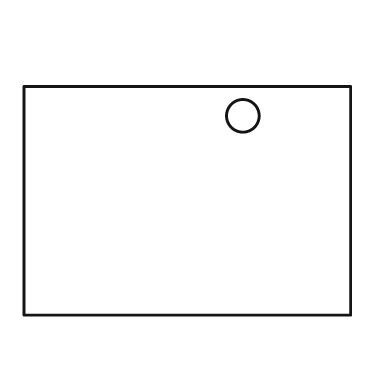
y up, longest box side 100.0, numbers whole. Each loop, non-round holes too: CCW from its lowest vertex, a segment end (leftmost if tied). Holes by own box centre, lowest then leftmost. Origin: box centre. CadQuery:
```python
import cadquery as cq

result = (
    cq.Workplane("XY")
    .moveTo(-50.0, -35.0)
    .lineTo(50.0, -35.0)
    .lineTo(50.0, 35.0)
    .lineTo(-50.0, 35.0)
    .close()
    .moveTo(17.0, 26.0)
    .circle(5.0)
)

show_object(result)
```